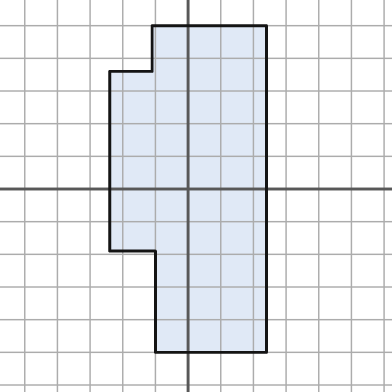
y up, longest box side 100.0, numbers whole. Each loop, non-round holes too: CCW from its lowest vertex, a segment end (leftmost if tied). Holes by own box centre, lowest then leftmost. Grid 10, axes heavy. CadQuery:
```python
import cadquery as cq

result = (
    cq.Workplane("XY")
    .moveTo(-10.0, -50.0)
    .lineTo(24.0, -50.0)
    .lineTo(24.0, 50.0)
    .lineTo(-11.0, 50.0)
    .lineTo(-11.0, 36.0)
    .lineTo(-24.0, 36.0)
    .lineTo(-24.0, -19.0)
    .lineTo(-10.0, -19.0)
    .close()
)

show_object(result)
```